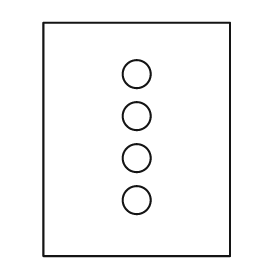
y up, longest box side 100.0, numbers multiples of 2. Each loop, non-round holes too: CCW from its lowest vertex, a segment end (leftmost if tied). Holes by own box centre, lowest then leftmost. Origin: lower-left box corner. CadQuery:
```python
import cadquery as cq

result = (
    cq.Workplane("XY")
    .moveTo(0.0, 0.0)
    .lineTo(80.0, 0.0)
    .lineTo(80.0, 100.0)
    .lineTo(0.0, 100.0)
    .close()
    .moveTo(40.0, 24.0)
    .circle(6.0)
    .moveTo(40.0, 42.0)
    .circle(6.0)
    .moveTo(40.0, 60.0)
    .circle(6.0)
    .moveTo(40.0, 78.0)
    .circle(6.0)
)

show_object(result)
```